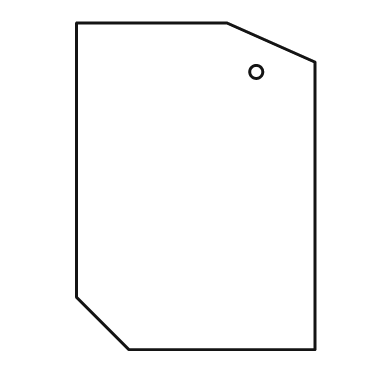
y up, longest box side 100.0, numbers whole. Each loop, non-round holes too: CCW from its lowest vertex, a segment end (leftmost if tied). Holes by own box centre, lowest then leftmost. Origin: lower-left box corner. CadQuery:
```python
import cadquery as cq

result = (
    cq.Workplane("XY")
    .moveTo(16.0, 0.0)
    .lineTo(73.0, 0.0)
    .lineTo(73.0, 88.0)
    .lineTo(46.0, 100.0)
    .lineTo(0.0, 100.0)
    .lineTo(0.0, 16.0)
    .close()
    .moveTo(55.0, 85.0)
    .circle(2.0)
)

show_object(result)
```